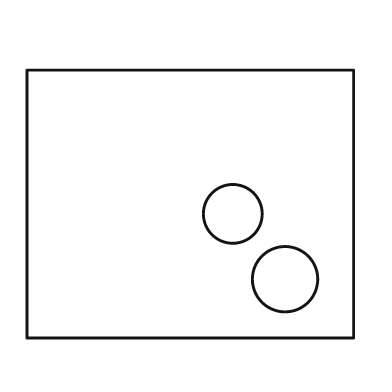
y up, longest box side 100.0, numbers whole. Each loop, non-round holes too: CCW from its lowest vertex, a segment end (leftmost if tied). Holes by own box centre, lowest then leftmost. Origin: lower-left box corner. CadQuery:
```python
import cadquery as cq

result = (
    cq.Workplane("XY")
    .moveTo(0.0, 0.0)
    .lineTo(100.0, 0.0)
    .lineTo(100.0, 82.0)
    .lineTo(0.0, 82.0)
    .close()
    .moveTo(79.0, 18.0)
    .circle(10.0)
    .moveTo(63.0, 38.0)
    .circle(9.0)
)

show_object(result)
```